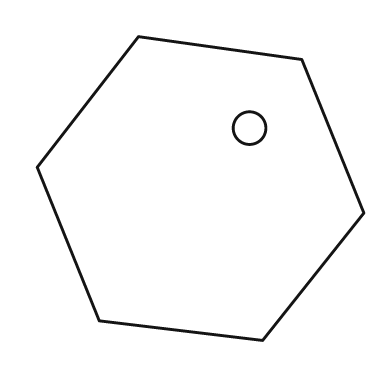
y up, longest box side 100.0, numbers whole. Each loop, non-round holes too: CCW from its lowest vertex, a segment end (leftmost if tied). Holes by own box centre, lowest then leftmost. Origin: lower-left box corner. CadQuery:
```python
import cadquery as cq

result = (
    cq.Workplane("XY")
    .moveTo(69.0, 0.0)
    .lineTo(100.0, 39.0)
    .lineTo(81.0, 86.0)
    .lineTo(31.0, 93.0)
    .lineTo(0.0, 53.0)
    .lineTo(19.0, 6.0)
    .close()
    .moveTo(65.0, 65.0)
    .circle(5.0)
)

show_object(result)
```